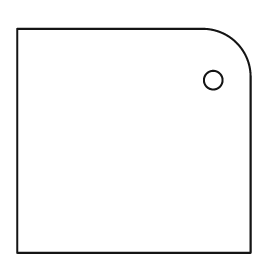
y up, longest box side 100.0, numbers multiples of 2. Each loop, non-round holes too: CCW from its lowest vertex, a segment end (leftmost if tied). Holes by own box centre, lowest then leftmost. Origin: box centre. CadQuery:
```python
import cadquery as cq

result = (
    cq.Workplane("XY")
    .moveTo(-50.0, -48.0)
    .lineTo(50.0, -48.0)
    .lineTo(50.0, 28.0)
    .threePointArc((44.0, 42.0), (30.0, 48.0))
    .lineTo(-50.0, 48.0)
    .close()
    .moveTo(34.0, 26.0)
    .circle(4.0)
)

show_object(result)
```